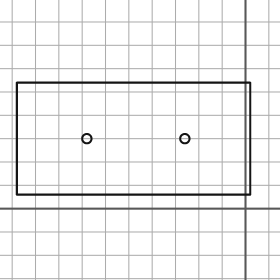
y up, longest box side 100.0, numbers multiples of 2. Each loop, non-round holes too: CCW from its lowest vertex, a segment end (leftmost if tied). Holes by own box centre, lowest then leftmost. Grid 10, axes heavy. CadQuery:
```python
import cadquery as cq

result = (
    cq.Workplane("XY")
    .moveTo(-98.0, 6.0)
    .lineTo(2.0, 6.0)
    .lineTo(2.0, 54.0)
    .lineTo(-98.0, 54.0)
    .close()
    .moveTo(-68.0, 30.0)
    .circle(2.0)
    .moveTo(-26.0, 30.0)
    .circle(2.0)
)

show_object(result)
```